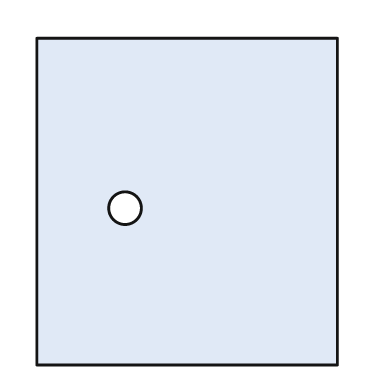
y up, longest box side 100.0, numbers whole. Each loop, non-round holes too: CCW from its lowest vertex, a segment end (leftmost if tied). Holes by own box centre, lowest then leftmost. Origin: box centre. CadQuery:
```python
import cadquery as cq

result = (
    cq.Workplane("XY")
    .moveTo(-46.0, -50.0)
    .lineTo(46.0, -50.0)
    .lineTo(46.0, 50.0)
    .lineTo(-46.0, 50.0)
    .close()
    .moveTo(-19.0, -2.0)
    .circle(5.0)
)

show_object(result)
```